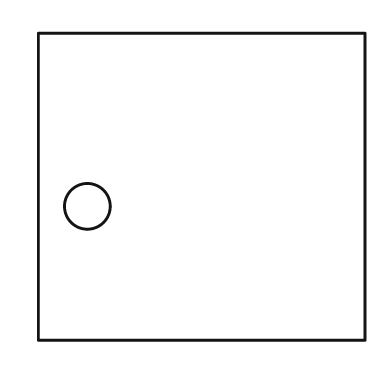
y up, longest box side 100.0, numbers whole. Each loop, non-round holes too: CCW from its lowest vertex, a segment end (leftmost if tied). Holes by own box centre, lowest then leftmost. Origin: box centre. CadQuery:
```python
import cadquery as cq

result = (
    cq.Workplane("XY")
    .moveTo(-50.0, -47.0)
    .lineTo(50.0, -47.0)
    .lineTo(50.0, 47.0)
    .lineTo(-50.0, 47.0)
    .close()
    .moveTo(-35.0, -6.0)
    .circle(7.0)
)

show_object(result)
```